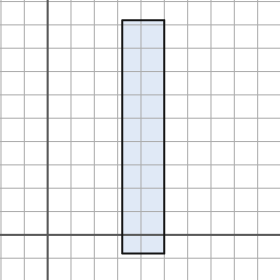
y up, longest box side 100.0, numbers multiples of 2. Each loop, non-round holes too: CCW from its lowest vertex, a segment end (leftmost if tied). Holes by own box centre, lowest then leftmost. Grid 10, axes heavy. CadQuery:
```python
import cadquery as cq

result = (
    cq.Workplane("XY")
    .moveTo(32.0, -8.0)
    .lineTo(50.0, -8.0)
    .lineTo(50.0, 92.0)
    .lineTo(32.0, 92.0)
    .close()
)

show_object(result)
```